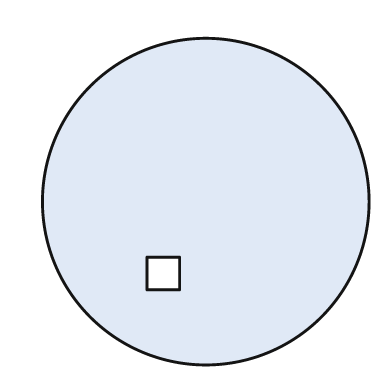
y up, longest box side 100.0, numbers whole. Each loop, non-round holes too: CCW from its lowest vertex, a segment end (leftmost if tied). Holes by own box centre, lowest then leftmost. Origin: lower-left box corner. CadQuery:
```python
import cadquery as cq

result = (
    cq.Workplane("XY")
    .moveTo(50.0, 50.0)
    .circle(50.0)
    .moveTo(32.0, 23.0)
    .lineTo(42.0, 23.0)
    .lineTo(42.0, 33.0)
    .lineTo(32.0, 33.0)
    .close()
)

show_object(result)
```